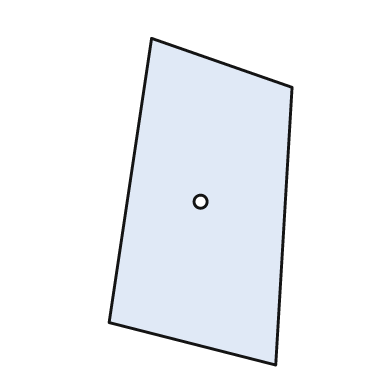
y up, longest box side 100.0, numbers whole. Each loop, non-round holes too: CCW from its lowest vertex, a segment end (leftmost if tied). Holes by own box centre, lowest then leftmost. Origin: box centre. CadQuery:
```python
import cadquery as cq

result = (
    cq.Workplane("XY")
    .moveTo(23.0, -50.0)
    .lineTo(28.0, 35.0)
    .lineTo(-15.0, 50.0)
    .lineTo(-28.0, -37.0)
    .close()
    .moveTo(0.0, 0.0)
    .circle(2.0)
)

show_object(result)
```